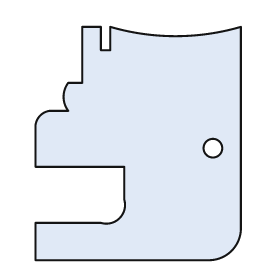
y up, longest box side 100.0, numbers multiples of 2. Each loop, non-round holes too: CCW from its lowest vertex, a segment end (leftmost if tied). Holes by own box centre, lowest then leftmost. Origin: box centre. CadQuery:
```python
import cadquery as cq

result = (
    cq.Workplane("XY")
    .moveTo(-44.0, -50.0)
    .lineTo(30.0, -50.0)
    .threePointArc((40.0, -46.0), (44.0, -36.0))
    .lineTo(44.0, 50.0)
    .threePointArc((16.0, 46.0), (-12.0, 50.0))
    .lineTo(-12.0, 40.0)
    .lineTo(-16.0, 40.0)
    .lineTo(-16.0, 50.0)
    .lineTo(-24.0, 50.0)
    .lineTo(-24.0, 26.0)
    .lineTo(-30.0, 26.0)
    .threePointArc((-32.0, 20.0), (-30.0, 14.0))
    .lineTo(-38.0, 14.0)
    .threePointArc((-42.0, 12.0), (-44.0, 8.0))
    .lineTo(-44.0, -10.0)
    .lineTo(-6.0, -10.0)
    .lineTo(-6.0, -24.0)
    .threePointArc((-8.0, -32.0), (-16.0, -34.0))
    .lineTo(-44.0, -34.0)
    .close()
    .moveTo(32.0, -2.0)
    .circle(4.0)
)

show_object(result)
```